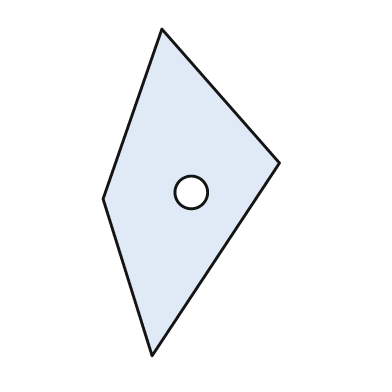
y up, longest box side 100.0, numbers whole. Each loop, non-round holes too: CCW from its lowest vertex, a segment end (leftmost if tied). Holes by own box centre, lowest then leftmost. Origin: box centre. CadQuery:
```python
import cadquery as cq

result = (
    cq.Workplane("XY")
    .moveTo(-12.0, -50.0)
    .lineTo(27.0, 9.0)
    .lineTo(-9.0, 50.0)
    .lineTo(-27.0, -2.0)
    .close()
    .moveTo(0.0, 0.0)
    .circle(5.0)
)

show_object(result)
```